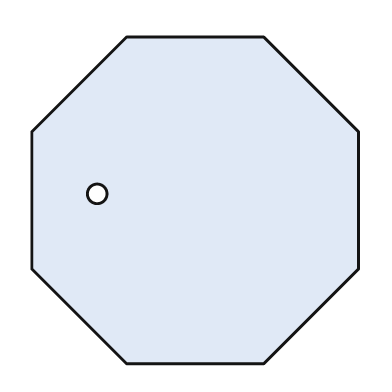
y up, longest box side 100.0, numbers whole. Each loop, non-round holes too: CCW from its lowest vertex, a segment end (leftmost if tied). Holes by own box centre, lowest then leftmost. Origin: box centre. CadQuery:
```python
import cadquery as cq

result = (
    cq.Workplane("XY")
    .moveTo(-21.0, -50.0)
    .lineTo(21.0, -50.0)
    .lineTo(50.0, -21.0)
    .lineTo(50.0, 21.0)
    .lineTo(21.0, 50.0)
    .lineTo(-21.0, 50.0)
    .lineTo(-50.0, 21.0)
    .lineTo(-50.0, -21.0)
    .close()
    .moveTo(-30.0, 2.0)
    .circle(3.0)
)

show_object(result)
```